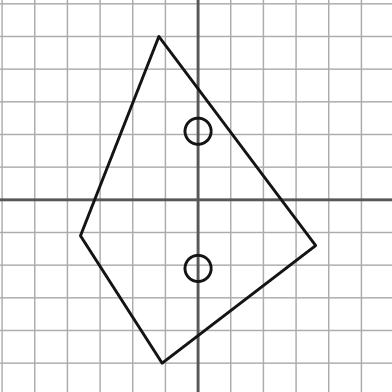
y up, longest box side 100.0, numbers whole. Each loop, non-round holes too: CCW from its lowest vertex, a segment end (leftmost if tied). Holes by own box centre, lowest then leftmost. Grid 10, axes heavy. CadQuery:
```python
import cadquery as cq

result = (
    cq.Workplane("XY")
    .moveTo(-11.0, -50.0)
    .lineTo(36.0, -14.0)
    .lineTo(-12.0, 50.0)
    .lineTo(-36.0, -11.0)
    .close()
    .moveTo(0.0, -21.0)
    .circle(4.0)
    .moveTo(0.0, 21.0)
    .circle(4.0)
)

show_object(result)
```